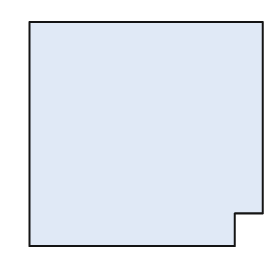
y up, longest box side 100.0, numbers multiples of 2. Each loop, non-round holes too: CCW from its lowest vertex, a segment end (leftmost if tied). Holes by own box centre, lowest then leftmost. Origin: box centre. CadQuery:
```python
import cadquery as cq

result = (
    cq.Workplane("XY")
    .moveTo(-50.0, -48.0)
    .lineTo(38.0, -48.0)
    .lineTo(38.0, -34.0)
    .lineTo(50.0, -34.0)
    .lineTo(50.0, 48.0)
    .lineTo(-50.0, 48.0)
    .close()
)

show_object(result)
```